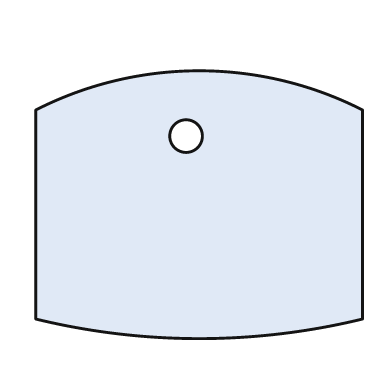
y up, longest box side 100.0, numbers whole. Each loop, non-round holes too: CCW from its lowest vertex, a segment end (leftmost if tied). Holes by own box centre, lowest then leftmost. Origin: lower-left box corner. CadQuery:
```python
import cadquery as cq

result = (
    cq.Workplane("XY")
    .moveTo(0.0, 6.0)
    .threePointArc((50.0, 0.0), (100.0, 6.0))
    .lineTo(100.0, 70.0)
    .threePointArc((50.0, 82.0), (0.0, 70.0))
    .close()
    .moveTo(46.0, 62.0)
    .circle(5.0)
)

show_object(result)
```